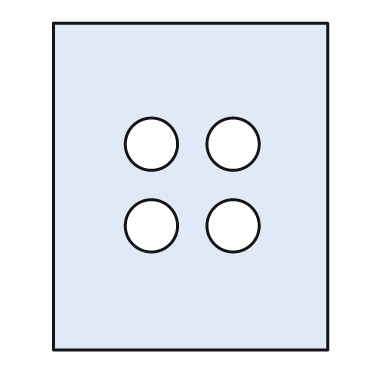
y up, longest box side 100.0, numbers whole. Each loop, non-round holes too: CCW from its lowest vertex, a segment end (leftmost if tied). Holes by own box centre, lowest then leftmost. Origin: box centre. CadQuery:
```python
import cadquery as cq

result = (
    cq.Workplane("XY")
    .moveTo(-42.0, -50.0)
    .lineTo(42.0, -50.0)
    .lineTo(42.0, 50.0)
    .lineTo(-42.0, 50.0)
    .close()
    .moveTo(-12.0, -12.0)
    .circle(8.0)
    .moveTo(13.0, -12.0)
    .circle(8.0)
    .moveTo(-12.0, 13.0)
    .circle(8.0)
    .moveTo(13.0, 13.0)
    .circle(8.0)
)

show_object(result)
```